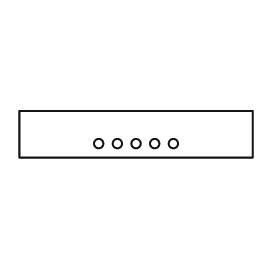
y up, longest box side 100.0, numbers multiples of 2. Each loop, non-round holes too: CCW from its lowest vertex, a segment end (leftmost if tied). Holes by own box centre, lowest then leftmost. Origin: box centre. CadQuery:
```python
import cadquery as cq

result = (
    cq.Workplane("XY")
    .moveTo(-50.0, -10.0)
    .lineTo(50.0, -10.0)
    .lineTo(50.0, 10.0)
    .lineTo(-50.0, 10.0)
    .close()
    .moveTo(-16.0, -4.0)
    .circle(2.0)
    .moveTo(-8.0, -4.0)
    .circle(2.0)
    .moveTo(0.0, -4.0)
    .circle(2.0)
    .moveTo(8.0, -4.0)
    .circle(2.0)
    .moveTo(16.0, -4.0)
    .circle(2.0)
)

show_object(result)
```